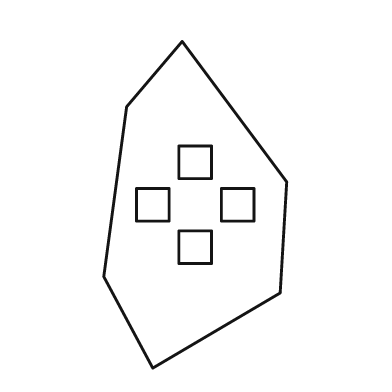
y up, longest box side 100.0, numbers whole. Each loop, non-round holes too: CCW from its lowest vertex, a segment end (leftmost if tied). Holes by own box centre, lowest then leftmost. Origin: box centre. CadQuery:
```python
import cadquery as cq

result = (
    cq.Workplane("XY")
    .moveTo(-13.0, -50.0)
    .lineTo(26.0, -27.0)
    .lineTo(28.0, 7.0)
    .lineTo(-4.0, 50.0)
    .lineTo(-21.0, 30.0)
    .lineTo(-28.0, -22.0)
    .close()
    .moveTo(-5.0, -18.0)
    .lineTo(5.0, -18.0)
    .lineTo(5.0, -8.0)
    .lineTo(-5.0, -8.0)
    .close()
    .moveTo(-18.0, -5.0)
    .lineTo(-8.0, -5.0)
    .lineTo(-8.0, 5.0)
    .lineTo(-18.0, 5.0)
    .close()
    .moveTo(8.0, -5.0)
    .lineTo(18.0, -5.0)
    .lineTo(18.0, 5.0)
    .lineTo(8.0, 5.0)
    .close()
    .moveTo(-5.0, 8.0)
    .lineTo(5.0, 8.0)
    .lineTo(5.0, 18.0)
    .lineTo(-5.0, 18.0)
    .close()
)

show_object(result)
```